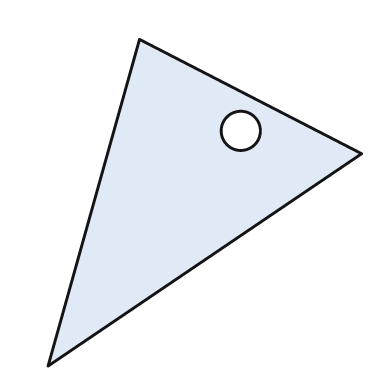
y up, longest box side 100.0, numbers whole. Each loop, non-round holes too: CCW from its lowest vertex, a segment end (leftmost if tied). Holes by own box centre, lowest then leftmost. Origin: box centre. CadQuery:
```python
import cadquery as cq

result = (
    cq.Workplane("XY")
    .moveTo(-48.0, -50.0)
    .lineTo(48.0, 15.0)
    .lineTo(-20.0, 50.0)
    .close()
    .moveTo(11.0, 22.0)
    .circle(6.0)
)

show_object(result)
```